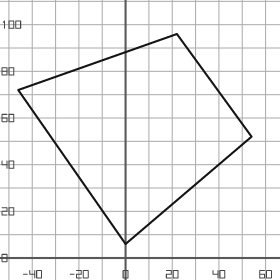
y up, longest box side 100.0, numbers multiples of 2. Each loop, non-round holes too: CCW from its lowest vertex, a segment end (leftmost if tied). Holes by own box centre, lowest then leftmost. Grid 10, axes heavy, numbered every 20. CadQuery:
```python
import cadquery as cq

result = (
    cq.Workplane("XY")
    .moveTo(0.0, 6.0)
    .lineTo(54.0, 52.0)
    .lineTo(22.0, 96.0)
    .lineTo(-46.0, 72.0)
    .close()
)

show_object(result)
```